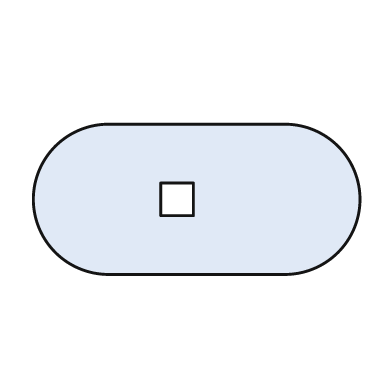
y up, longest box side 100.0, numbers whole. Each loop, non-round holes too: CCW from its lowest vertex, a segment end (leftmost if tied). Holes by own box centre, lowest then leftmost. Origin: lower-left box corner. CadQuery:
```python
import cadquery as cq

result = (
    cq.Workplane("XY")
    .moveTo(23.0, 0.0)
    .lineTo(77.0, 0.0)
    .threePointArc((100.0, 23.0), (77.0, 46.0))
    .lineTo(23.0, 46.0)
    .threePointArc((0.0, 23.0), (23.0, 0.0))
    .close()
    .moveTo(39.0, 18.0)
    .lineTo(49.0, 18.0)
    .lineTo(49.0, 28.0)
    .lineTo(39.0, 28.0)
    .close()
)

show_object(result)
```